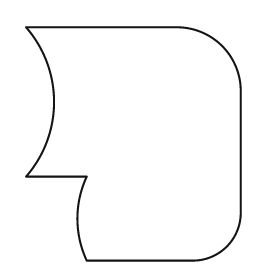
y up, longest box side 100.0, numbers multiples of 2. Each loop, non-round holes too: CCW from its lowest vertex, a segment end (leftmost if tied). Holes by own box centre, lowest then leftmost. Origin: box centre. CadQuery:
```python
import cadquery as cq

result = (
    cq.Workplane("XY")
    .moveTo(-20.0, -50.0)
    .lineTo(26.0, -50.0)
    .threePointArc((40.0, -44.0), (46.0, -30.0))
    .lineTo(46.0, 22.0)
    .threePointArc((38.0, 42.0), (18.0, 50.0))
    .lineTo(-46.0, 50.0)
    .threePointArc((-34.0, 18.0), (-46.0, -14.0))
    .lineTo(-20.0, -14.0)
    .threePointArc((-24.0, -32.0), (-20.0, -50.0))
    .close()
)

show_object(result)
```